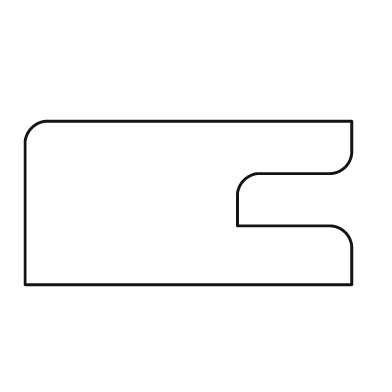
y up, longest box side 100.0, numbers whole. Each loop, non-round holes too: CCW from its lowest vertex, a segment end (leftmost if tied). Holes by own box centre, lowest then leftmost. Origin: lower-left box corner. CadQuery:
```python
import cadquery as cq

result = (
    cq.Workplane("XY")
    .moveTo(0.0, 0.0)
    .lineTo(100.0, 0.0)
    .lineTo(100.0, 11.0)
    .threePointArc((98.0, 16.0), (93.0, 18.0))
    .lineTo(65.0, 18.0)
    .lineTo(65.0, 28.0)
    .threePointArc((67.0, 32.0), (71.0, 34.0))
    .lineTo(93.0, 34.0)
    .threePointArc((98.0, 36.0), (100.0, 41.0))
    .lineTo(100.0, 50.0)
    .lineTo(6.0, 50.0)
    .threePointArc((2.0, 48.0), (0.0, 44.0))
    .close()
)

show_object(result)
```